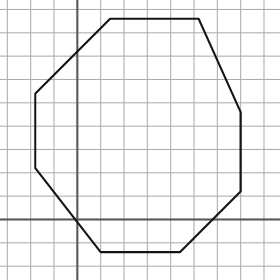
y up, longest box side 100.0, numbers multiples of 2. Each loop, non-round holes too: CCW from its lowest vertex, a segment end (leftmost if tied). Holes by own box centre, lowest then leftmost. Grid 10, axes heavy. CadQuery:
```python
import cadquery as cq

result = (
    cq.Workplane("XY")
    .moveTo(10.0, -14.0)
    .lineTo(44.0, -14.0)
    .lineTo(70.0, 12.0)
    .lineTo(70.0, 46.0)
    .lineTo(52.0, 86.0)
    .lineTo(14.0, 86.0)
    .lineTo(-18.0, 54.0)
    .lineTo(-18.0, 22.0)
    .close()
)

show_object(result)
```